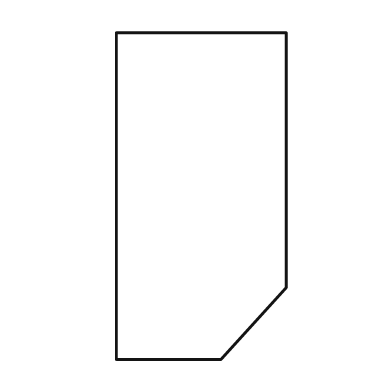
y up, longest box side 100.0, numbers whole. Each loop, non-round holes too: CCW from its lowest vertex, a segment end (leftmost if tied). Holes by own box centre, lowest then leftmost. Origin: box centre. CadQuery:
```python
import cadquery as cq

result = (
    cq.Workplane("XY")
    .moveTo(-26.0, -50.0)
    .lineTo(6.0, -50.0)
    .lineTo(26.0, -28.0)
    .lineTo(26.0, 50.0)
    .lineTo(-26.0, 50.0)
    .close()
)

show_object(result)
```